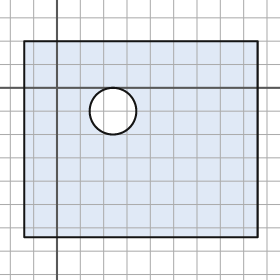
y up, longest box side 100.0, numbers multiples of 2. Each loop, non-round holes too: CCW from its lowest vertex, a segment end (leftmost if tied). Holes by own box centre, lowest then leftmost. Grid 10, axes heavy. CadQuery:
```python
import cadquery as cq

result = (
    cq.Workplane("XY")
    .moveTo(-14.0, -64.0)
    .lineTo(86.0, -64.0)
    .lineTo(86.0, 20.0)
    .lineTo(-14.0, 20.0)
    .close()
    .moveTo(24.0, -10.0)
    .circle(10.0)
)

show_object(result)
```